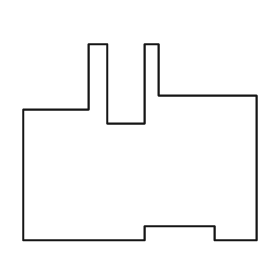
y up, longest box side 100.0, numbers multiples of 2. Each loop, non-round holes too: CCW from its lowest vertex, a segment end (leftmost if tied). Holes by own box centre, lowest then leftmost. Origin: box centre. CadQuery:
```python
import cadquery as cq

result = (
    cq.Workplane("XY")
    .moveTo(-50.0, -42.0)
    .lineTo(2.0, -42.0)
    .lineTo(2.0, -36.0)
    .lineTo(32.0, -36.0)
    .lineTo(32.0, -42.0)
    .lineTo(50.0, -42.0)
    .lineTo(50.0, 20.0)
    .lineTo(8.0, 20.0)
    .lineTo(8.0, 42.0)
    .lineTo(2.0, 42.0)
    .lineTo(2.0, 8.0)
    .lineTo(-14.0, 8.0)
    .lineTo(-14.0, 42.0)
    .lineTo(-22.0, 42.0)
    .lineTo(-22.0, 14.0)
    .lineTo(-50.0, 14.0)
    .close()
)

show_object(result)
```